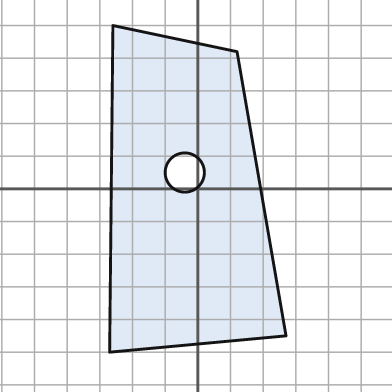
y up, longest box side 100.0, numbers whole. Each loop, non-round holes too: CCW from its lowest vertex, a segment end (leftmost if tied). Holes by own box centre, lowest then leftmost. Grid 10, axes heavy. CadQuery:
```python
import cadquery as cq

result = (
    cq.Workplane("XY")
    .moveTo(-27.0, -50.0)
    .lineTo(27.0, -45.0)
    .lineTo(12.0, 42.0)
    .lineTo(-26.0, 50.0)
    .close()
    .moveTo(-4.0, 5.0)
    .circle(6.0)
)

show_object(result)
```